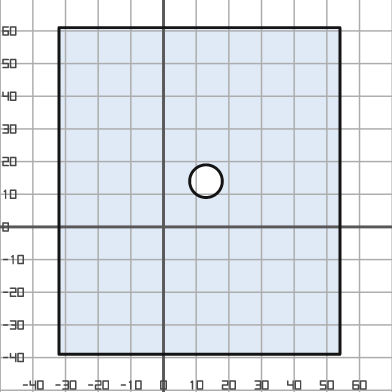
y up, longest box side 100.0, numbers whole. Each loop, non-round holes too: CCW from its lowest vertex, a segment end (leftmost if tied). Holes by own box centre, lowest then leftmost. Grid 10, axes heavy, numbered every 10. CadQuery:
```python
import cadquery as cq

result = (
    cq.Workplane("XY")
    .moveTo(-32.0, -39.0)
    .lineTo(54.0, -39.0)
    .lineTo(54.0, 61.0)
    .lineTo(-32.0, 61.0)
    .close()
    .moveTo(13.0, 14.0)
    .circle(5.0)
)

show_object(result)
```